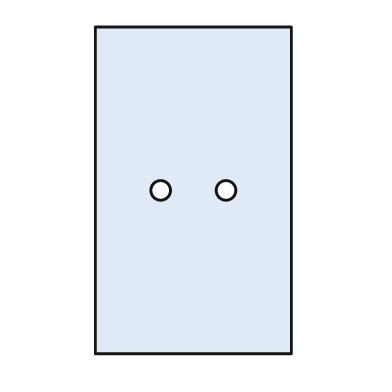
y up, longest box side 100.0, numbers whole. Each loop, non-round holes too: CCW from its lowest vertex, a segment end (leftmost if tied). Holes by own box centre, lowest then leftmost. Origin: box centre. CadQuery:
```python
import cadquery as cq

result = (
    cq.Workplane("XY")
    .moveTo(-30.0, -50.0)
    .lineTo(30.0, -50.0)
    .lineTo(30.0, 50.0)
    .lineTo(-30.0, 50.0)
    .close()
    .moveTo(-10.0, 0.0)
    .circle(3.0)
    .moveTo(10.0, 0.0)
    .circle(3.0)
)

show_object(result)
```